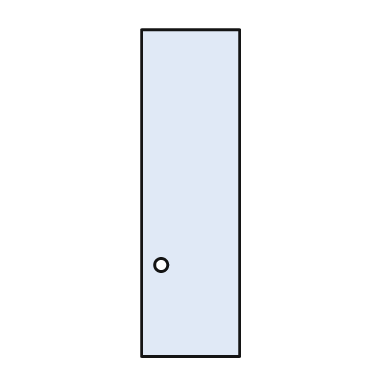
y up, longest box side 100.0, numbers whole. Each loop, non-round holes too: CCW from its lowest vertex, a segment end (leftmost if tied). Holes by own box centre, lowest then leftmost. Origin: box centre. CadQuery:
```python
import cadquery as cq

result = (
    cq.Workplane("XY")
    .moveTo(-15.0, -50.0)
    .lineTo(15.0, -50.0)
    .lineTo(15.0, 50.0)
    .lineTo(-15.0, 50.0)
    .close()
    .moveTo(-9.0, -22.0)
    .circle(2.0)
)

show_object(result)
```